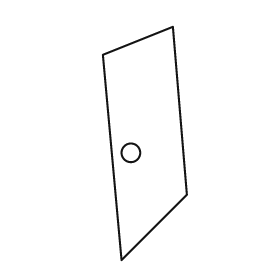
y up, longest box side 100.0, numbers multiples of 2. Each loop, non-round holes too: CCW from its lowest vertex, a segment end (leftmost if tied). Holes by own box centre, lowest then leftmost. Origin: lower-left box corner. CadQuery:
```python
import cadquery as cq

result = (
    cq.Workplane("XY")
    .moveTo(8.0, 0.0)
    .lineTo(36.0, 28.0)
    .lineTo(30.0, 100.0)
    .lineTo(0.0, 88.0)
    .close()
    .moveTo(12.0, 46.0)
    .circle(4.0)
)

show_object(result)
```